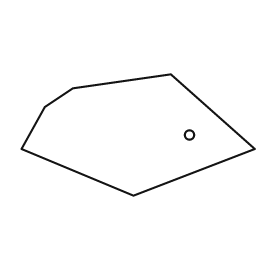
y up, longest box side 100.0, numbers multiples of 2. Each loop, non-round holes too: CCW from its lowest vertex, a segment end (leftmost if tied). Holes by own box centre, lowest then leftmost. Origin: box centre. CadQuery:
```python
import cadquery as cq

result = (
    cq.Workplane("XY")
    .moveTo(-2.0, -26.0)
    .lineTo(50.0, -6.0)
    .lineTo(14.0, 26.0)
    .lineTo(-28.0, 20.0)
    .lineTo(-40.0, 12.0)
    .lineTo(-50.0, -6.0)
    .close()
    .moveTo(22.0, 0.0)
    .circle(2.0)
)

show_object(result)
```